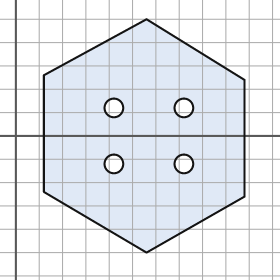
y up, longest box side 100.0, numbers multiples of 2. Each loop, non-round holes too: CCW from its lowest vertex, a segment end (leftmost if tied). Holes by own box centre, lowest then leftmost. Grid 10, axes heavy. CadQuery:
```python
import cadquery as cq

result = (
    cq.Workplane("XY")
    .moveTo(56.0, -50.0)
    .lineTo(98.0, -26.0)
    .lineTo(98.0, 24.0)
    .lineTo(56.0, 50.0)
    .lineTo(12.0, 26.0)
    .lineTo(12.0, -24.0)
    .close()
    .moveTo(42.0, -12.0)
    .circle(4.0)
    .moveTo(72.0, -12.0)
    .circle(4.0)
    .moveTo(42.0, 12.0)
    .circle(4.0)
    .moveTo(72.0, 12.0)
    .circle(4.0)
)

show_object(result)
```